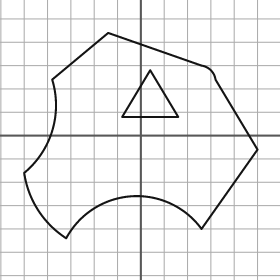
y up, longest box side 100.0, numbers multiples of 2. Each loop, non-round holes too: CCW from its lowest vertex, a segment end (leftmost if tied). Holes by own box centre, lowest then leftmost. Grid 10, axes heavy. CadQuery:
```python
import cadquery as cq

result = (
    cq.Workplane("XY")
    .moveTo(-32.0, -44.0)
    .threePointArc((-4.0, -26.0), (26.0, -40.0))
    .lineTo(50.0, -6.0)
    .lineTo(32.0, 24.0)
    .threePointArc((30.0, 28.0), (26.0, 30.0))
    .lineTo(-14.0, 44.0)
    .lineTo(-38.0, 24.0)
    .threePointArc((-38.0, 2.0), (-50.0, -16.0))
    .threePointArc((-44.0, -32.0), (-32.0, -44.0))
    .close()
    .moveTo(-8.0, 8.0)
    .lineTo(16.0, 8.0)
    .lineTo(4.0, 28.0)
    .close()
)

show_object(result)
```